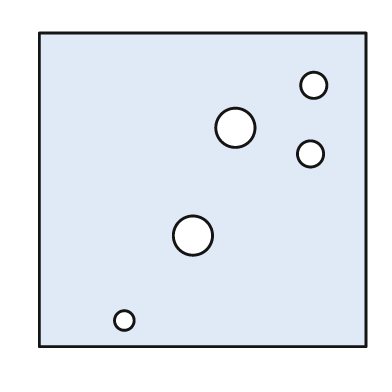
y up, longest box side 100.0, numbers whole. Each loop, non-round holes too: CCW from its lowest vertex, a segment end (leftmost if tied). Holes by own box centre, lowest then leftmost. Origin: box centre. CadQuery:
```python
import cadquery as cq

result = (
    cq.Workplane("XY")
    .moveTo(-50.0, -48.0)
    .lineTo(50.0, -48.0)
    .lineTo(50.0, 48.0)
    .lineTo(-50.0, 48.0)
    .close()
    .moveTo(-24.0, -40.0)
    .circle(3.0)
    .moveTo(-3.0, -14.0)
    .circle(6.0)
    .moveTo(33.0, 11.0)
    .circle(4.0)
    .moveTo(10.0, 19.0)
    .circle(6.0)
    .moveTo(34.0, 32.0)
    .circle(4.0)
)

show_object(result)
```